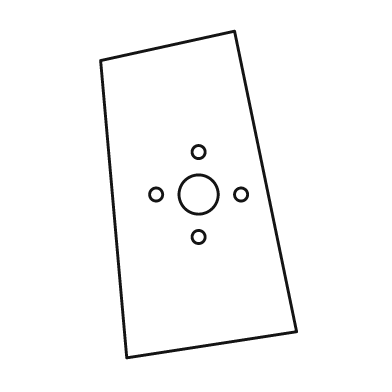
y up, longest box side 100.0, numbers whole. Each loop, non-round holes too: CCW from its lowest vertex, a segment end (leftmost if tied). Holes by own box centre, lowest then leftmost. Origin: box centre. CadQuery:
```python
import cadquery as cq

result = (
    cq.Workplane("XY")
    .moveTo(-22.0, -50.0)
    .lineTo(30.0, -42.0)
    .lineTo(11.0, 50.0)
    .lineTo(-30.0, 41.0)
    .close()
    .moveTo(0.0, -13.0)
    .circle(2.0)
    .moveTo(-13.0, 0.0)
    .circle(2.0)
    .moveTo(0.0, 0.0)
    .circle(6.0)
    .moveTo(13.0, 0.0)
    .circle(2.0)
    .moveTo(0.0, 13.0)
    .circle(2.0)
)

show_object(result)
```